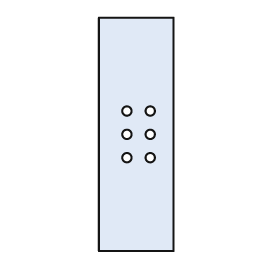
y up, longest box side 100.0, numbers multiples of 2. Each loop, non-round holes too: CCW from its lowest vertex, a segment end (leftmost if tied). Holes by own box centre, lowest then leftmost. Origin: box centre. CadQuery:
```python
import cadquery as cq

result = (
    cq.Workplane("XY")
    .moveTo(-16.0, -50.0)
    .lineTo(16.0, -50.0)
    .lineTo(16.0, 50.0)
    .lineTo(-16.0, 50.0)
    .close()
    .moveTo(-4.0, -10.0)
    .circle(2.0)
    .moveTo(6.0, -10.0)
    .circle(2.0)
    .moveTo(-4.0, 0.0)
    .circle(2.0)
    .moveTo(6.0, 0.0)
    .circle(2.0)
    .moveTo(-4.0, 10.0)
    .circle(2.0)
    .moveTo(6.0, 10.0)
    .circle(2.0)
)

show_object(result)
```